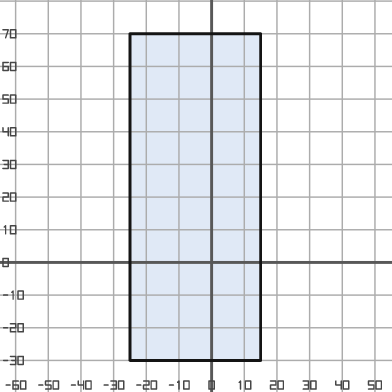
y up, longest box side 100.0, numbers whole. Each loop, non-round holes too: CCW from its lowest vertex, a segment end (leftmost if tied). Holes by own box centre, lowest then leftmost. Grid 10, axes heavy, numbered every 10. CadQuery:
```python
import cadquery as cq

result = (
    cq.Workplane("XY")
    .moveTo(-25.0, -30.0)
    .lineTo(15.0, -30.0)
    .lineTo(15.0, 70.0)
    .lineTo(-25.0, 70.0)
    .close()
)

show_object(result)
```